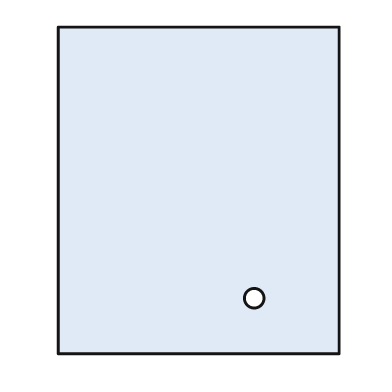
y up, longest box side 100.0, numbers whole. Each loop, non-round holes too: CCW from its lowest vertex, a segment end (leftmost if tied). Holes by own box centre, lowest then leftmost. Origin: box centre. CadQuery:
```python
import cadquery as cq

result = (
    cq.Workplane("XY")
    .moveTo(-43.0, -50.0)
    .lineTo(43.0, -50.0)
    .lineTo(43.0, 50.0)
    .lineTo(-43.0, 50.0)
    .close()
    .moveTo(17.0, -33.0)
    .circle(3.0)
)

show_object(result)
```